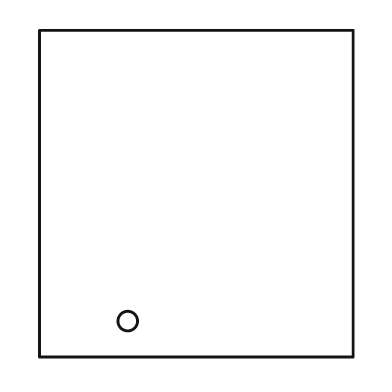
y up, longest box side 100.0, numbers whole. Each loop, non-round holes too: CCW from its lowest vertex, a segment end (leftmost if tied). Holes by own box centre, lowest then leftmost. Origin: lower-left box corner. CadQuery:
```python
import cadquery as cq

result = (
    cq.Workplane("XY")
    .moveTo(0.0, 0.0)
    .lineTo(96.0, 0.0)
    .lineTo(96.0, 100.0)
    .lineTo(0.0, 100.0)
    .close()
    .moveTo(27.0, 11.0)
    .circle(3.0)
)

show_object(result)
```